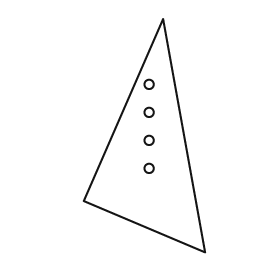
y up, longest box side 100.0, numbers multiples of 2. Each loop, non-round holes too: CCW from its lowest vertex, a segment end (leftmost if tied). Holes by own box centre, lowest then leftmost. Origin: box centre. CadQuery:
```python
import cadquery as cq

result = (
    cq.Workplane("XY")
    .moveTo(26.0, -50.0)
    .lineTo(8.0, 50.0)
    .lineTo(-26.0, -28.0)
    .close()
    .moveTo(2.0, -14.0)
    .circle(2.0)
    .moveTo(2.0, -2.0)
    .circle(2.0)
    .moveTo(2.0, 10.0)
    .circle(2.0)
    .moveTo(2.0, 22.0)
    .circle(2.0)
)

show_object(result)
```